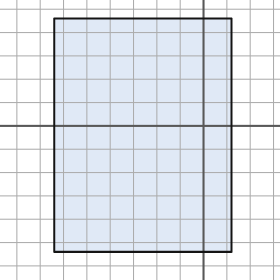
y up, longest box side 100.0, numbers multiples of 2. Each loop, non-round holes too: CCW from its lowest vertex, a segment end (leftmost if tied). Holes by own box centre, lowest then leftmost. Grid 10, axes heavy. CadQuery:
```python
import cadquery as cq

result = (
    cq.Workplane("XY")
    .moveTo(-64.0, -54.0)
    .lineTo(12.0, -54.0)
    .lineTo(12.0, 46.0)
    .lineTo(-64.0, 46.0)
    .close()
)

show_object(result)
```